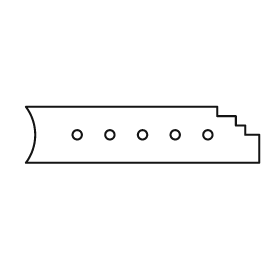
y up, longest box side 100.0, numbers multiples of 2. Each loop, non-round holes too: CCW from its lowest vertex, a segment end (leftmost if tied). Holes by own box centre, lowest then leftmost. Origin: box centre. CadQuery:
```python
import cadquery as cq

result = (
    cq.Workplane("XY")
    .moveTo(-50.0, -12.0)
    .lineTo(50.0, -12.0)
    .lineTo(50.0, 0.0)
    .lineTo(44.0, 0.0)
    .lineTo(44.0, 4.0)
    .lineTo(40.0, 4.0)
    .lineTo(40.0, 8.0)
    .lineTo(32.0, 8.0)
    .lineTo(32.0, 12.0)
    .lineTo(-50.0, 12.0)
    .threePointArc((-46.0, 0.0), (-50.0, -12.0))
    .close()
    .moveTo(-28.0, 0.0)
    .circle(2.0)
    .moveTo(-14.0, 0.0)
    .circle(2.0)
    .moveTo(0.0, 0.0)
    .circle(2.0)
    .moveTo(14.0, 0.0)
    .circle(2.0)
    .moveTo(28.0, 0.0)
    .circle(2.0)
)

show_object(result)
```